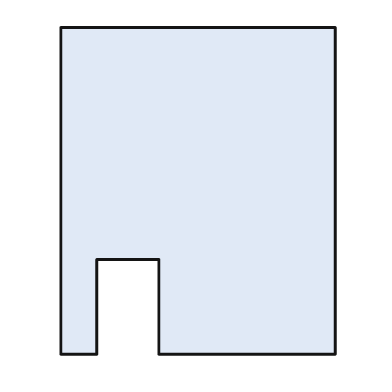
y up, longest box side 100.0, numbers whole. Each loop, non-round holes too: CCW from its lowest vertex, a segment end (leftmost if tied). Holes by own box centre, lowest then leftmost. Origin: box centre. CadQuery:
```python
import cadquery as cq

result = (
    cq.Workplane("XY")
    .moveTo(-42.0, -50.0)
    .lineTo(-31.0, -50.0)
    .lineTo(-31.0, -21.0)
    .lineTo(-12.0, -21.0)
    .lineTo(-12.0, -50.0)
    .lineTo(42.0, -50.0)
    .lineTo(42.0, 50.0)
    .lineTo(-42.0, 50.0)
    .close()
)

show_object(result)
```